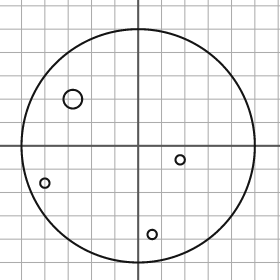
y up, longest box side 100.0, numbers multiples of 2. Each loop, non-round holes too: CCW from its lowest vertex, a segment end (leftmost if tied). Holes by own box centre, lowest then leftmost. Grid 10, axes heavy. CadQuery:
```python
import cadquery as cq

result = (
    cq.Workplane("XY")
    .moveTo(0.0, 0.0)
    .circle(50.0)
    .moveTo(6.0, -38.0)
    .circle(2.0)
    .moveTo(-40.0, -16.0)
    .circle(2.0)
    .moveTo(18.0, -6.0)
    .circle(2.0)
    .moveTo(-28.0, 20.0)
    .circle(4.0)
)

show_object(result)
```